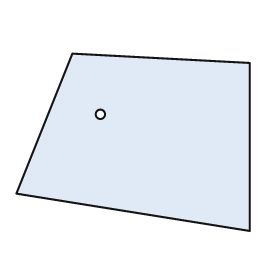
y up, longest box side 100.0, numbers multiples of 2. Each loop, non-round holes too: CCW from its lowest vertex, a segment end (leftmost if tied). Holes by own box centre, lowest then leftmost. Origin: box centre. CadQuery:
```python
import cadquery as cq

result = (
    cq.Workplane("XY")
    .moveTo(50.0, -38.0)
    .lineTo(50.0, 34.0)
    .lineTo(-26.0, 38.0)
    .lineTo(-50.0, -22.0)
    .close()
    .moveTo(-14.0, 12.0)
    .circle(2.0)
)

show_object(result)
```